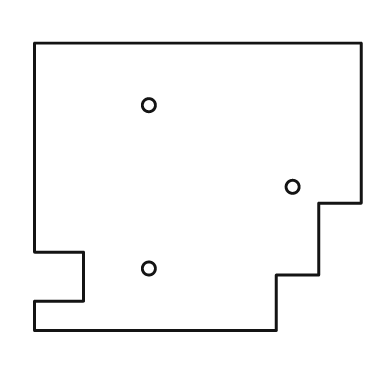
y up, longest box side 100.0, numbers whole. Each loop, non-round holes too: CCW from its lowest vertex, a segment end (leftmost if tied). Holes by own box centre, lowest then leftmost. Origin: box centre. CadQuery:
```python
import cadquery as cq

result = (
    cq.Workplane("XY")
    .moveTo(-50.0, -44.0)
    .lineTo(24.0, -44.0)
    .lineTo(24.0, -27.0)
    .lineTo(37.0, -27.0)
    .lineTo(37.0, -5.0)
    .lineTo(50.0, -5.0)
    .lineTo(50.0, 44.0)
    .lineTo(-50.0, 44.0)
    .lineTo(-50.0, -20.0)
    .lineTo(-35.0, -20.0)
    .lineTo(-35.0, -35.0)
    .lineTo(-50.0, -35.0)
    .close()
    .moveTo(-15.0, -25.0)
    .circle(2.0)
    .moveTo(29.0, 0.0)
    .circle(2.0)
    .moveTo(-15.0, 25.0)
    .circle(2.0)
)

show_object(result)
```